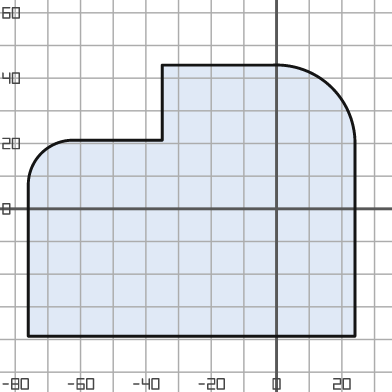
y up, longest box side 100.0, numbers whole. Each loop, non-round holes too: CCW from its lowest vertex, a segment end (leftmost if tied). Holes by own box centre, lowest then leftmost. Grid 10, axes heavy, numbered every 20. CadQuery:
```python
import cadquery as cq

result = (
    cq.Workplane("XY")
    .moveTo(-76.0, -39.0)
    .lineTo(24.0, -39.0)
    .lineTo(24.0, 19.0)
    .threePointArc((17.0, 37.0), (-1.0, 44.0))
    .lineTo(-35.0, 44.0)
    .lineTo(-35.0, 21.0)
    .lineTo(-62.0, 21.0)
    .threePointArc((-72.0, 17.0), (-76.0, 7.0))
    .close()
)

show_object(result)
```